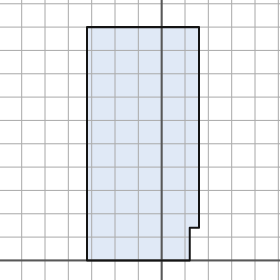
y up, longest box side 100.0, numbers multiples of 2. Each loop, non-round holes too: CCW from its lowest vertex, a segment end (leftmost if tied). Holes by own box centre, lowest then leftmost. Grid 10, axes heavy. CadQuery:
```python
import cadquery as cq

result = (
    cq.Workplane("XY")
    .moveTo(-32.0, 0.0)
    .lineTo(12.0, 0.0)
    .lineTo(12.0, 14.0)
    .lineTo(16.0, 14.0)
    .lineTo(16.0, 100.0)
    .lineTo(-32.0, 100.0)
    .close()
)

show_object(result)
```